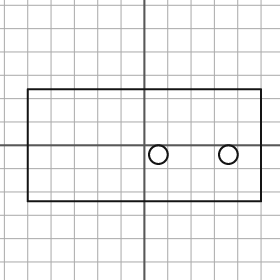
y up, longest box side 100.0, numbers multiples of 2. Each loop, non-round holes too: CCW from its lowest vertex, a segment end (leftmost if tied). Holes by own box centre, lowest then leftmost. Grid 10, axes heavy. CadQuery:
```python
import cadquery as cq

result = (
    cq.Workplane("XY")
    .moveTo(-50.0, -24.0)
    .lineTo(50.0, -24.0)
    .lineTo(50.0, 24.0)
    .lineTo(-50.0, 24.0)
    .close()
    .moveTo(6.0, -4.0)
    .circle(4.0)
    .moveTo(36.0, -4.0)
    .circle(4.0)
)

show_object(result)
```